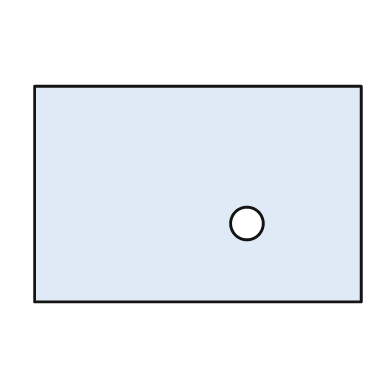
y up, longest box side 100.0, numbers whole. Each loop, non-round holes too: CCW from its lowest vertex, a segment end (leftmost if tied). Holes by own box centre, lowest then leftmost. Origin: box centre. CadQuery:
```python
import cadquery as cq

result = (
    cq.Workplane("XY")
    .moveTo(-50.0, -33.0)
    .lineTo(50.0, -33.0)
    .lineTo(50.0, 33.0)
    .lineTo(-50.0, 33.0)
    .close()
    .moveTo(15.0, -9.0)
    .circle(5.0)
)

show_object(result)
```